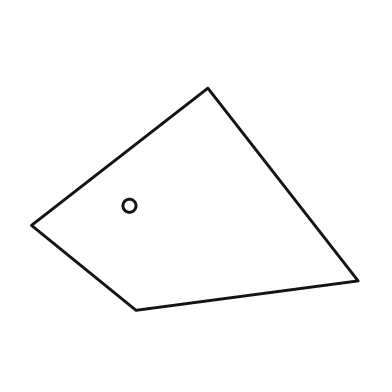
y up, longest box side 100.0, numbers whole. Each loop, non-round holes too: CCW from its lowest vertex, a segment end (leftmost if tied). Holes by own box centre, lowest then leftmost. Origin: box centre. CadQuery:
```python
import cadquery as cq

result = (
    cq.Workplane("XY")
    .moveTo(-18.0, -34.0)
    .lineTo(50.0, -25.0)
    .lineTo(4.0, 34.0)
    .lineTo(-50.0, -8.0)
    .close()
    .moveTo(-20.0, -2.0)
    .circle(2.0)
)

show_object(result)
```